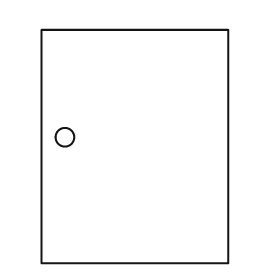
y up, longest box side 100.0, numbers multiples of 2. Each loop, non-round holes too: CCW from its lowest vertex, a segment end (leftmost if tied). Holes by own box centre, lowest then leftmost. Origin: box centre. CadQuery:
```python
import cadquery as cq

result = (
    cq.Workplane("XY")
    .moveTo(-40.0, -50.0)
    .lineTo(40.0, -50.0)
    .lineTo(40.0, 50.0)
    .lineTo(-40.0, 50.0)
    .close()
    .moveTo(-30.0, 4.0)
    .circle(4.0)
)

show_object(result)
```